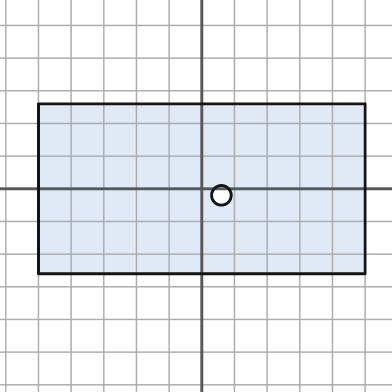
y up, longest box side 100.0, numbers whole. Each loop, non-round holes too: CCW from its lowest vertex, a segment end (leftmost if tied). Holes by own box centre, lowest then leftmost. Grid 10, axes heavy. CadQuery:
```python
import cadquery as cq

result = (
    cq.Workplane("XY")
    .moveTo(-50.0, -26.0)
    .lineTo(50.0, -26.0)
    .lineTo(50.0, 26.0)
    .lineTo(-50.0, 26.0)
    .close()
    .moveTo(6.0, -2.0)
    .circle(3.0)
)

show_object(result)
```